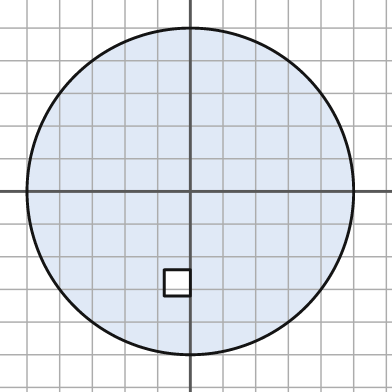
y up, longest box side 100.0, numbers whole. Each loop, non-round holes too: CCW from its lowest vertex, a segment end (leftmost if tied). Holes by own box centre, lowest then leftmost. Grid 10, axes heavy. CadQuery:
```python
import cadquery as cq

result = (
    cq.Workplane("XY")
    .moveTo(0.0, 0.0)
    .circle(50.0)
    .moveTo(-8.0, -32.0)
    .lineTo(0.0, -32.0)
    .lineTo(0.0, -24.0)
    .lineTo(-8.0, -24.0)
    .close()
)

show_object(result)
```